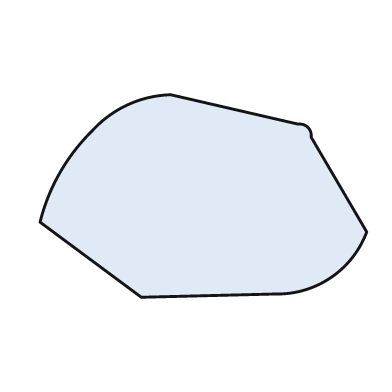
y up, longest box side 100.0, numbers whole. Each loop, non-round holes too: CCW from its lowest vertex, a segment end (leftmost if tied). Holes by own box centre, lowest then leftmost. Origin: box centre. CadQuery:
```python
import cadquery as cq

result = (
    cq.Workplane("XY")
    .moveTo(-19.0, -31.0)
    .lineTo(22.0, -30.0)
    .threePointArc((39.0, -25.0), (50.0, -11.0))
    .lineTo(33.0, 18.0)
    .threePointArc((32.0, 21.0), (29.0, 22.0))
    .lineTo(-10.0, 31.0)
    .threePointArc((-23.0, 28.0), (-34.0, 20.0))
    .threePointArc((-44.0, 7.0), (-50.0, -8.0))
    .close()
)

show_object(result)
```